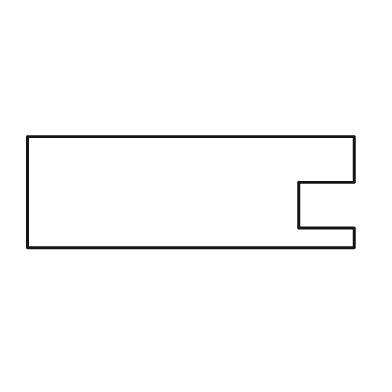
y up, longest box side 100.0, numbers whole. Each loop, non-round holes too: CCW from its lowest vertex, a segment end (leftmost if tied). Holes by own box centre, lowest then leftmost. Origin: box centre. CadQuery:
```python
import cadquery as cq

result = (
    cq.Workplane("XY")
    .moveTo(-50.0, -17.0)
    .lineTo(50.0, -17.0)
    .lineTo(50.0, -11.0)
    .lineTo(33.0, -11.0)
    .lineTo(33.0, 3.0)
    .lineTo(50.0, 3.0)
    .lineTo(50.0, 17.0)
    .lineTo(-50.0, 17.0)
    .close()
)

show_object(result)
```